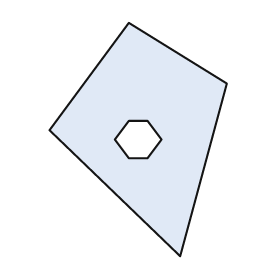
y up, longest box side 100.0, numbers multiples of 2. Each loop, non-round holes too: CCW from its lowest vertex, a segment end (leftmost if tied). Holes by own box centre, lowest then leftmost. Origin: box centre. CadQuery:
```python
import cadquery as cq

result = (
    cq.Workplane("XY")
    .moveTo(18.0, -50.0)
    .lineTo(38.0, 24.0)
    .lineTo(-4.0, 50.0)
    .lineTo(-38.0, 4.0)
    .close()
    .moveTo(-4.0, -8.0)
    .lineTo(4.0, -8.0)
    .lineTo(10.0, 0.0)
    .lineTo(4.0, 8.0)
    .lineTo(-4.0, 8.0)
    .lineTo(-10.0, 0.0)
    .close()
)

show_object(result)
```